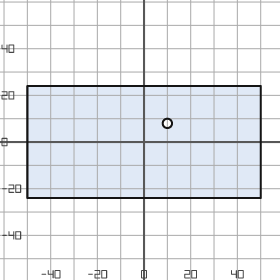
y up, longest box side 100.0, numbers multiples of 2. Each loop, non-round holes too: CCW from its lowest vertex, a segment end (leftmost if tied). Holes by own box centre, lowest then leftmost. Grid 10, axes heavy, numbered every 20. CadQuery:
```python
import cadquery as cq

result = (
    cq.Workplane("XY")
    .moveTo(-50.0, -24.0)
    .lineTo(50.0, -24.0)
    .lineTo(50.0, 24.0)
    .lineTo(-50.0, 24.0)
    .close()
    .moveTo(10.0, 8.0)
    .circle(2.0)
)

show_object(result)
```